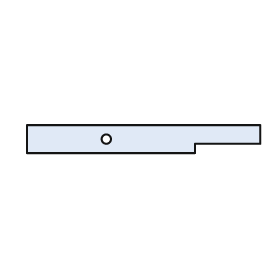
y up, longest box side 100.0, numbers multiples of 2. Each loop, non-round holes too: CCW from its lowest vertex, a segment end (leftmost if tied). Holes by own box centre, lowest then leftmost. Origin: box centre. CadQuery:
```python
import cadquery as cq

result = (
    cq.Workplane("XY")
    .moveTo(-50.0, -6.0)
    .lineTo(22.0, -6.0)
    .lineTo(22.0, -2.0)
    .lineTo(50.0, -2.0)
    .lineTo(50.0, 6.0)
    .lineTo(-50.0, 6.0)
    .close()
    .moveTo(-16.0, 0.0)
    .circle(2.0)
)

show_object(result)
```